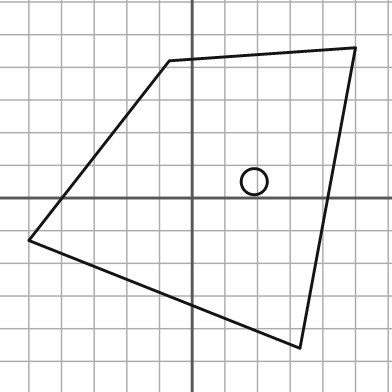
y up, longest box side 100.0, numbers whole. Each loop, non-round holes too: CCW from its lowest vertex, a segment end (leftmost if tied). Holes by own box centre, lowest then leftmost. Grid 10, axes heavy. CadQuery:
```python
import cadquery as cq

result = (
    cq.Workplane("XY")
    .moveTo(33.0, -46.0)
    .lineTo(50.0, 46.0)
    .lineTo(-7.0, 42.0)
    .lineTo(-50.0, -13.0)
    .close()
    .moveTo(19.0, 5.0)
    .circle(4.0)
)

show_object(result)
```